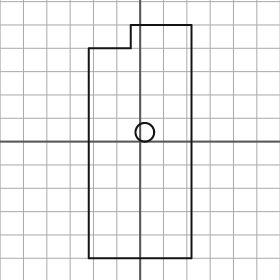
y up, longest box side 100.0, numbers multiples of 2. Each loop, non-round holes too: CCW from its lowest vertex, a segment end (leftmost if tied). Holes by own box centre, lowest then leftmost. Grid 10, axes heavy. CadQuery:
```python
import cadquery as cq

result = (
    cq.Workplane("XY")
    .moveTo(-22.0, -50.0)
    .lineTo(22.0, -50.0)
    .lineTo(22.0, 50.0)
    .lineTo(-4.0, 50.0)
    .lineTo(-4.0, 40.0)
    .lineTo(-22.0, 40.0)
    .close()
    .moveTo(2.0, 4.0)
    .circle(4.0)
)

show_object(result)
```